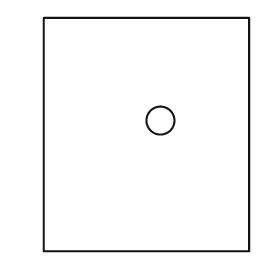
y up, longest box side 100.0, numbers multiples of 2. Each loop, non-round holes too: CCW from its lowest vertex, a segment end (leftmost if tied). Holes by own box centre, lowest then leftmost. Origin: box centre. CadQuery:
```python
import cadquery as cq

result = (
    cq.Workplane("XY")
    .moveTo(-44.0, -50.0)
    .lineTo(44.0, -50.0)
    .lineTo(44.0, 50.0)
    .lineTo(-44.0, 50.0)
    .close()
    .moveTo(6.0, 6.0)
    .circle(6.0)
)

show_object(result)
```